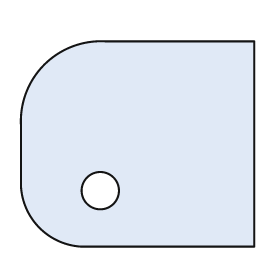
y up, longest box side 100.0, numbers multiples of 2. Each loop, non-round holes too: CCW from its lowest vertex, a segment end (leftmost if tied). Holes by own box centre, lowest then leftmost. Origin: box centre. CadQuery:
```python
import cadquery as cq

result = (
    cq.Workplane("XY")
    .moveTo(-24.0, -44.0)
    .lineTo(50.0, -44.0)
    .lineTo(50.0, 44.0)
    .lineTo(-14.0, 44.0)
    .threePointArc((-40.0, 34.0), (-50.0, 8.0))
    .lineTo(-50.0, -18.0)
    .threePointArc((-42.0, -36.0), (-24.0, -44.0))
    .close()
    .moveTo(-16.0, -20.0)
    .circle(8.0)
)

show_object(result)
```